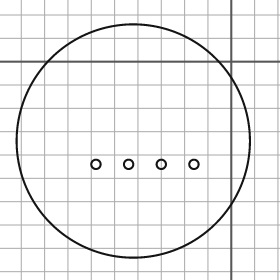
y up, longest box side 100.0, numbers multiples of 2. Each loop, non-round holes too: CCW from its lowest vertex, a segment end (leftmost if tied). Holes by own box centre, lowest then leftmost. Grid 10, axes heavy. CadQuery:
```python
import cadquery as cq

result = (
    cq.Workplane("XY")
    .moveTo(-42.0, -34.0)
    .circle(50.0)
    .moveTo(-58.0, -44.0)
    .circle(2.0)
    .moveTo(-44.0, -44.0)
    .circle(2.0)
    .moveTo(-30.0, -44.0)
    .circle(2.0)
    .moveTo(-16.0, -44.0)
    .circle(2.0)
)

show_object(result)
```